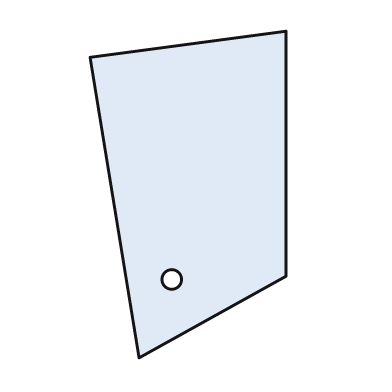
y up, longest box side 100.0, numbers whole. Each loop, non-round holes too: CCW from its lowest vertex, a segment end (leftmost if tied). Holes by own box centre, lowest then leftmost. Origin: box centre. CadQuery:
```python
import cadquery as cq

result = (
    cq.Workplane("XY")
    .moveTo(-15.0, -50.0)
    .lineTo(30.0, -25.0)
    .lineTo(30.0, 50.0)
    .lineTo(-30.0, 42.0)
    .close()
    .moveTo(-5.0, -26.0)
    .circle(3.0)
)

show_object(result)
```